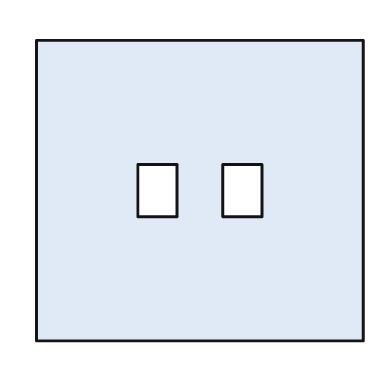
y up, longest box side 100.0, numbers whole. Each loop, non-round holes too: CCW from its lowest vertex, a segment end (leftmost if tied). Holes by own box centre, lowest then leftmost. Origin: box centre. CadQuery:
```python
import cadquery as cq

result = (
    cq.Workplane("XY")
    .moveTo(-50.0, -46.0)
    .lineTo(50.0, -46.0)
    .lineTo(50.0, 46.0)
    .lineTo(-50.0, 46.0)
    .close()
    .moveTo(-19.0, -8.0)
    .lineTo(-7.0, -8.0)
    .lineTo(-7.0, 8.0)
    .lineTo(-19.0, 8.0)
    .close()
    .moveTo(7.0, -8.0)
    .lineTo(19.0, -8.0)
    .lineTo(19.0, 8.0)
    .lineTo(7.0, 8.0)
    .close()
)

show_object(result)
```